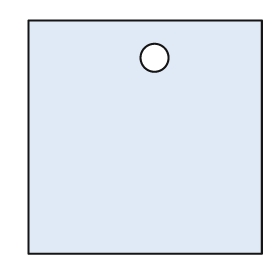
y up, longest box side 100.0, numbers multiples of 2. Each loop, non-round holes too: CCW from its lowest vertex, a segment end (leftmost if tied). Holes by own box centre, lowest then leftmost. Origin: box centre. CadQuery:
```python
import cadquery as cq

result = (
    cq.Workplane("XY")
    .moveTo(-50.0, -50.0)
    .lineTo(50.0, -50.0)
    .lineTo(50.0, 50.0)
    .lineTo(-50.0, 50.0)
    .close()
    .moveTo(4.0, 34.0)
    .circle(6.0)
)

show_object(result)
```